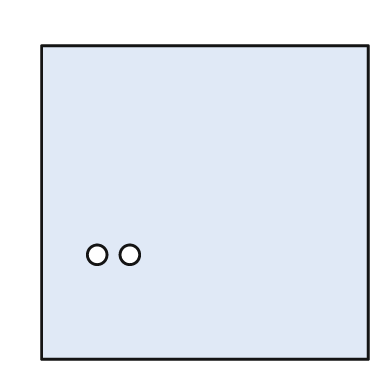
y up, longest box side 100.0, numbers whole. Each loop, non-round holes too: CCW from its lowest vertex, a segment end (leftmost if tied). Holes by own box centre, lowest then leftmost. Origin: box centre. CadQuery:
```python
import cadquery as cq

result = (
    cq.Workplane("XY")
    .moveTo(-50.0, -48.0)
    .lineTo(50.0, -48.0)
    .lineTo(50.0, 48.0)
    .lineTo(-50.0, 48.0)
    .close()
    .moveTo(-33.0, -16.0)
    .circle(3.0)
    .moveTo(-23.0, -16.0)
    .circle(3.0)
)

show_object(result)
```